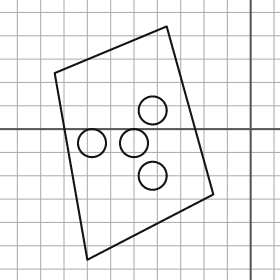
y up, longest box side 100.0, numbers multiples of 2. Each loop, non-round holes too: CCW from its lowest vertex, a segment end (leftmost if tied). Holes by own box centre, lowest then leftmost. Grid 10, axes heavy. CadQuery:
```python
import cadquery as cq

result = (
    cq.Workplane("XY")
    .moveTo(-70.0, -56.0)
    .lineTo(-16.0, -28.0)
    .lineTo(-36.0, 44.0)
    .lineTo(-84.0, 24.0)
    .close()
    .moveTo(-42.0, -20.0)
    .circle(6.0)
    .moveTo(-68.0, -6.0)
    .circle(6.0)
    .moveTo(-50.0, -6.0)
    .circle(6.0)
    .moveTo(-42.0, 8.0)
    .circle(6.0)
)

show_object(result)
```